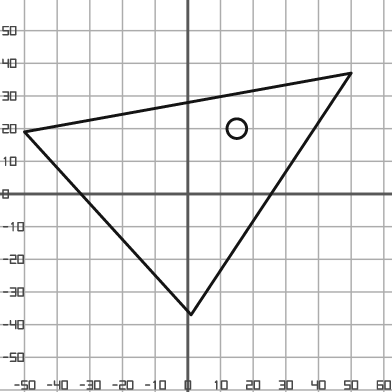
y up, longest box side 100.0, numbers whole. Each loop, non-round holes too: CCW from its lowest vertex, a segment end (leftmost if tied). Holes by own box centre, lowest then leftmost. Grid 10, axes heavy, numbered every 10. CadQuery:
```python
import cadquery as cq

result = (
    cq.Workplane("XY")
    .moveTo(1.0, -37.0)
    .lineTo(50.0, 37.0)
    .lineTo(-50.0, 19.0)
    .close()
    .moveTo(15.0, 20.0)
    .circle(3.0)
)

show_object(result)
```